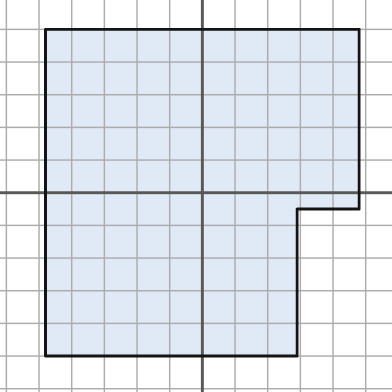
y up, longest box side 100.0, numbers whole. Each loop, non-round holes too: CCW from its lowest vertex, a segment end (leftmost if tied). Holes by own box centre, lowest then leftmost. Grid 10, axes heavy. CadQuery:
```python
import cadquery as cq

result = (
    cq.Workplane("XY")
    .moveTo(-48.0, -50.0)
    .lineTo(29.0, -50.0)
    .lineTo(29.0, -5.0)
    .lineTo(48.0, -5.0)
    .lineTo(48.0, 50.0)
    .lineTo(-48.0, 50.0)
    .close()
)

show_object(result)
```